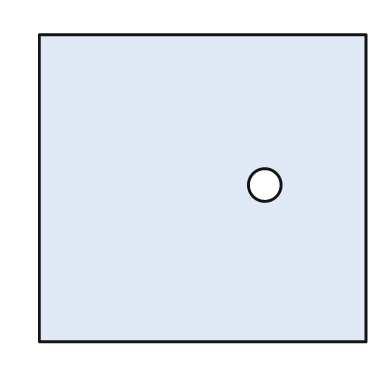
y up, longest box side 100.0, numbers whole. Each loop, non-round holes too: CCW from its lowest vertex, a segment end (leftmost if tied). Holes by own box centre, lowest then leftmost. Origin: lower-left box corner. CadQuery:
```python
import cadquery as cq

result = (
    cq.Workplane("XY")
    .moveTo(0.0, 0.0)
    .lineTo(100.0, 0.0)
    .lineTo(100.0, 94.0)
    .lineTo(0.0, 94.0)
    .close()
    .moveTo(69.0, 48.0)
    .circle(5.0)
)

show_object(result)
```